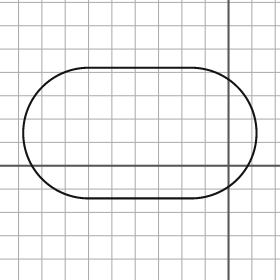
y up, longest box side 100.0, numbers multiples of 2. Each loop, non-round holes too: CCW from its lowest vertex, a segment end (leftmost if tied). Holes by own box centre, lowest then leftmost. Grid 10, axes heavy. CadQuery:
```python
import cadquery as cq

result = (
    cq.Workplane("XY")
    .moveTo(-60.0, -14.0)
    .lineTo(-16.0, -14.0)
    .threePointArc((12.0, 14.0), (-16.0, 42.0))
    .lineTo(-60.0, 42.0)
    .threePointArc((-88.0, 14.0), (-60.0, -14.0))
    .close()
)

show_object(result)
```